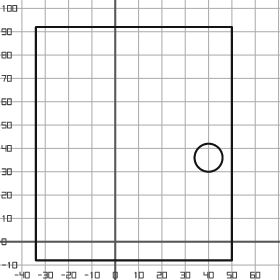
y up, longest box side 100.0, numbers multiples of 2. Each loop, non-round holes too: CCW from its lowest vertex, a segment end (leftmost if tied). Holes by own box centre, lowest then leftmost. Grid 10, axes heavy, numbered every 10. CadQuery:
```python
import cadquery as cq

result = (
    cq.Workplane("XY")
    .moveTo(-34.0, -8.0)
    .lineTo(50.0, -8.0)
    .lineTo(50.0, 92.0)
    .lineTo(-34.0, 92.0)
    .close()
    .moveTo(40.0, 36.0)
    .circle(6.0)
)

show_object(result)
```